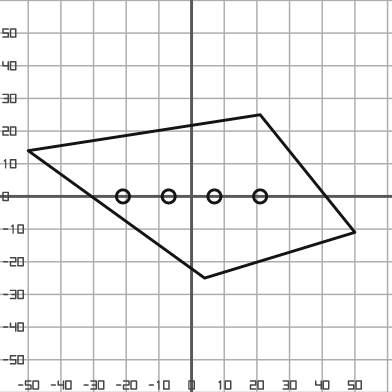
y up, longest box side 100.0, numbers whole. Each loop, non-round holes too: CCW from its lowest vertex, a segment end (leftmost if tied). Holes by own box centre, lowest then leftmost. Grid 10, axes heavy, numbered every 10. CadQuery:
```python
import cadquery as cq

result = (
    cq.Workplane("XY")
    .moveTo(4.0, -25.0)
    .lineTo(50.0, -11.0)
    .lineTo(21.0, 25.0)
    .lineTo(-50.0, 14.0)
    .close()
    .moveTo(-21.0, 0.0)
    .circle(2.0)
    .moveTo(-7.0, 0.0)
    .circle(2.0)
    .moveTo(7.0, 0.0)
    .circle(2.0)
    .moveTo(21.0, 0.0)
    .circle(2.0)
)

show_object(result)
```